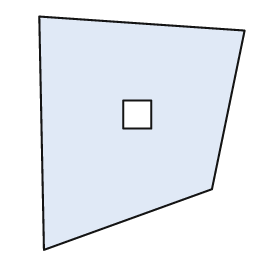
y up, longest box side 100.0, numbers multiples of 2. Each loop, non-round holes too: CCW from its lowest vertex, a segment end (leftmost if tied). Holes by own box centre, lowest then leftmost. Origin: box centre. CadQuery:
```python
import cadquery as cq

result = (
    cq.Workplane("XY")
    .moveTo(-42.0, -50.0)
    .lineTo(30.0, -24.0)
    .lineTo(44.0, 44.0)
    .lineTo(-44.0, 50.0)
    .close()
    .moveTo(-8.0, 2.0)
    .lineTo(4.0, 2.0)
    .lineTo(4.0, 14.0)
    .lineTo(-8.0, 14.0)
    .close()
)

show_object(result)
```